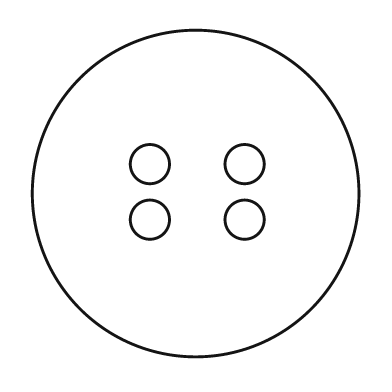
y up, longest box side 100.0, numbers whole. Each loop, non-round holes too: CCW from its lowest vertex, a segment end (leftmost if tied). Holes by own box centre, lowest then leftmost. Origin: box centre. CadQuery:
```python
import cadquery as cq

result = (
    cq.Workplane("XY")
    .moveTo(0.0, 0.0)
    .circle(50.0)
    .moveTo(-14.0, -8.0)
    .circle(6.0)
    .moveTo(15.0, -8.0)
    .circle(6.0)
    .moveTo(-14.0, 9.0)
    .circle(6.0)
    .moveTo(15.0, 9.0)
    .circle(6.0)
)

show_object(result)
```